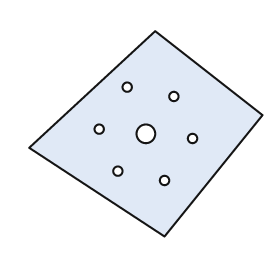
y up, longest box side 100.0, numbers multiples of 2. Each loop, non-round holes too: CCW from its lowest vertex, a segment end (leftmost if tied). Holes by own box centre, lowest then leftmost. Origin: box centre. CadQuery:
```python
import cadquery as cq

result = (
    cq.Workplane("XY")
    .moveTo(8.0, -44.0)
    .lineTo(50.0, 8.0)
    .lineTo(4.0, 44.0)
    .lineTo(-50.0, -6.0)
    .close()
    .moveTo(8.0, -20.0)
    .circle(2.0)
    .moveTo(-12.0, -16.0)
    .circle(2.0)
    .moveTo(20.0, -2.0)
    .circle(2.0)
    .moveTo(0.0, 0.0)
    .circle(4.0)
    .moveTo(-20.0, 2.0)
    .circle(2.0)
    .moveTo(12.0, 16.0)
    .circle(2.0)
    .moveTo(-8.0, 20.0)
    .circle(2.0)
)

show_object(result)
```